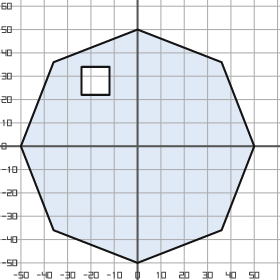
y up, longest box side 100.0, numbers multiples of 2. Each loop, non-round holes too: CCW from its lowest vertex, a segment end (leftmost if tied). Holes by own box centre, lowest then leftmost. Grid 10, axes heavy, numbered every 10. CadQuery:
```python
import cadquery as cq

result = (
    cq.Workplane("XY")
    .moveTo(0.0, -50.0)
    .lineTo(36.0, -36.0)
    .lineTo(50.0, 0.0)
    .lineTo(36.0, 36.0)
    .lineTo(0.0, 50.0)
    .lineTo(-36.0, 36.0)
    .lineTo(-50.0, 0.0)
    .lineTo(-36.0, -36.0)
    .close()
    .moveTo(-24.0, 22.0)
    .lineTo(-12.0, 22.0)
    .lineTo(-12.0, 34.0)
    .lineTo(-24.0, 34.0)
    .close()
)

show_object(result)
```